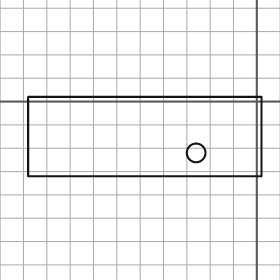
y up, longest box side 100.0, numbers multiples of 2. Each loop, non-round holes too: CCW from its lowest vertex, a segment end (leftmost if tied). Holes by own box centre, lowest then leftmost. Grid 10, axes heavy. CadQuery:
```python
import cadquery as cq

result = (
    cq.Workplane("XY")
    .moveTo(-98.0, -32.0)
    .lineTo(2.0, -32.0)
    .lineTo(2.0, 2.0)
    .lineTo(-98.0, 2.0)
    .close()
    .moveTo(-26.0, -22.0)
    .circle(4.0)
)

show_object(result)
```